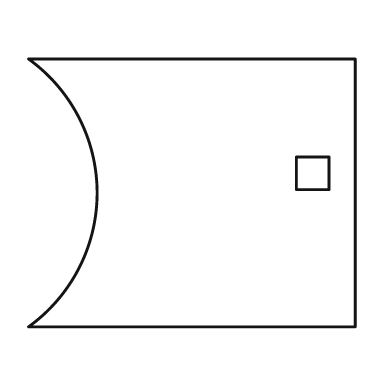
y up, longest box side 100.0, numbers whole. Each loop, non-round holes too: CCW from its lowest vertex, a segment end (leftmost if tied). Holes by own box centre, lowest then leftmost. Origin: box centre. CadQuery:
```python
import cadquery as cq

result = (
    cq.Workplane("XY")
    .moveTo(-50.0, -41.0)
    .lineTo(50.0, -41.0)
    .lineTo(50.0, 41.0)
    .lineTo(-50.0, 41.0)
    .threePointArc((-29.0, 0.0), (-50.0, -41.0))
    .close()
    .moveTo(32.0, 1.0)
    .lineTo(42.0, 1.0)
    .lineTo(42.0, 11.0)
    .lineTo(32.0, 11.0)
    .close()
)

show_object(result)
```